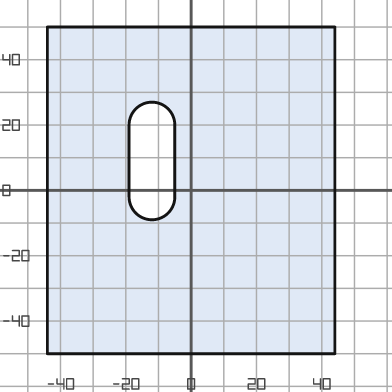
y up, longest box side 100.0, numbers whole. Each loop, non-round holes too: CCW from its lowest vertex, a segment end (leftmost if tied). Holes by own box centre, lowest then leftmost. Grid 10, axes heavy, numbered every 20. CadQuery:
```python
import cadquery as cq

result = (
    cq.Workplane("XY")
    .moveTo(-44.0, -50.0)
    .lineTo(44.0, -50.0)
    .lineTo(44.0, 50.0)
    .lineTo(-44.0, 50.0)
    .close()
    .moveTo(-19.0, -2.0)
    .threePointArc((-12.0, -9.0), (-5.0, -2.0))
    .lineTo(-5.0, 20.0)
    .threePointArc((-12.0, 27.0), (-19.0, 20.0))
    .close()
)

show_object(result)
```